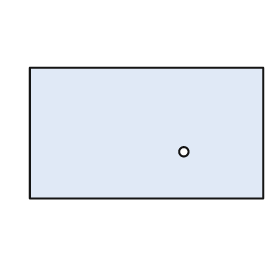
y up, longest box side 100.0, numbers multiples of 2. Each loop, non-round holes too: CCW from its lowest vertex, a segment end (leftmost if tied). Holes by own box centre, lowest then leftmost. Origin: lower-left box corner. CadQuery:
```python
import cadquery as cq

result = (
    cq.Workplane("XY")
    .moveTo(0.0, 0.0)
    .lineTo(100.0, 0.0)
    .lineTo(100.0, 56.0)
    .lineTo(0.0, 56.0)
    .close()
    .moveTo(66.0, 20.0)
    .circle(2.0)
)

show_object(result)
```